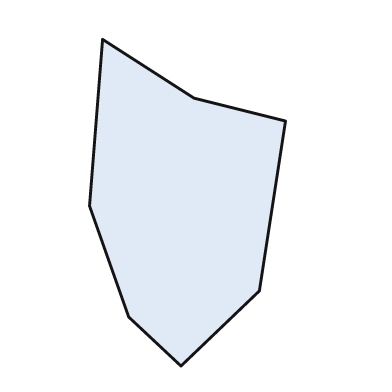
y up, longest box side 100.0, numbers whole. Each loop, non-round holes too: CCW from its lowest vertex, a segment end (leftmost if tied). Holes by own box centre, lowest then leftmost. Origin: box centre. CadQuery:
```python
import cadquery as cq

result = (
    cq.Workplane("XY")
    .moveTo(-2.0, -50.0)
    .lineTo(22.0, -27.0)
    .lineTo(30.0, 25.0)
    .lineTo(2.0, 32.0)
    .lineTo(-26.0, 50.0)
    .lineTo(-30.0, -1.0)
    .lineTo(-18.0, -35.0)
    .close()
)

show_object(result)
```